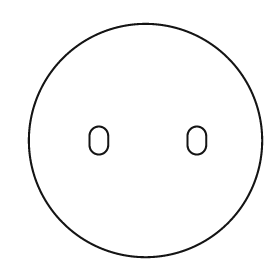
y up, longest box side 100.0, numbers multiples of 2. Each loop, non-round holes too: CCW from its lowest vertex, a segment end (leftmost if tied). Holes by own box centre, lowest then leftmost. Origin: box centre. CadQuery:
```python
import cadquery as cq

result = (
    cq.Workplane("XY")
    .moveTo(0.0, 0.0)
    .circle(50.0)
    .moveTo(-24.0, -2.0)
    .threePointArc((-20.0, -6.0), (-16.0, -2.0))
    .lineTo(-16.0, 2.0)
    .threePointArc((-20.0, 6.0), (-24.0, 2.0))
    .close()
    .moveTo(18.0, -2.0)
    .threePointArc((22.0, -6.0), (26.0, -2.0))
    .lineTo(26.0, 2.0)
    .threePointArc((22.0, 6.0), (18.0, 2.0))
    .close()
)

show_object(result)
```